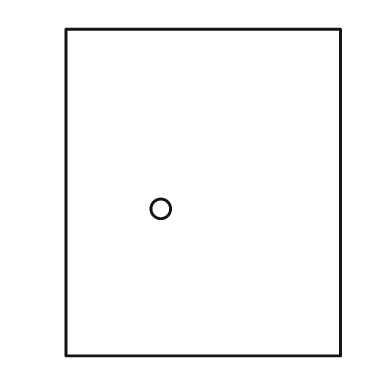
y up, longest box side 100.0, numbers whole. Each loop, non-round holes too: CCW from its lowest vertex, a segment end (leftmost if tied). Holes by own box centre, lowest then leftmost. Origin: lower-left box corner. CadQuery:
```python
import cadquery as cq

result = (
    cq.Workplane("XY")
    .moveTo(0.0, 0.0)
    .lineTo(84.0, 0.0)
    .lineTo(84.0, 100.0)
    .lineTo(0.0, 100.0)
    .close()
    .moveTo(29.0, 45.0)
    .circle(3.0)
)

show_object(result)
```